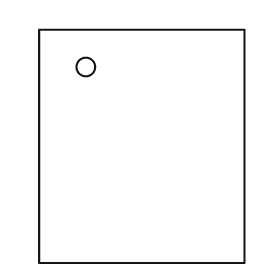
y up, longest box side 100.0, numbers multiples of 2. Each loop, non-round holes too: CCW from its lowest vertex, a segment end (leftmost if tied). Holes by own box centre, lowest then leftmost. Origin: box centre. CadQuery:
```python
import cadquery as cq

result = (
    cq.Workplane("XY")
    .moveTo(-44.0, -50.0)
    .lineTo(44.0, -50.0)
    .lineTo(44.0, 50.0)
    .lineTo(-44.0, 50.0)
    .close()
    .moveTo(-24.0, 34.0)
    .circle(4.0)
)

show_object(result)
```